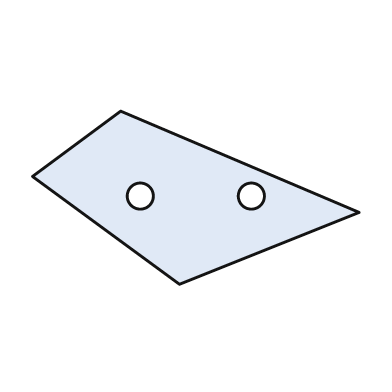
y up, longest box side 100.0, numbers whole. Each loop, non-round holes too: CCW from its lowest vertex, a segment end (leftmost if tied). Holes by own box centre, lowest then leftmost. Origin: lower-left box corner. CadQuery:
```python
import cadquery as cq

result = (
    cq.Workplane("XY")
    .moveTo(45.0, 0.0)
    .lineTo(100.0, 22.0)
    .lineTo(27.0, 53.0)
    .lineTo(0.0, 33.0)
    .close()
    .moveTo(33.0, 27.0)
    .circle(4.0)
    .moveTo(67.0, 27.0)
    .circle(4.0)
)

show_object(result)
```